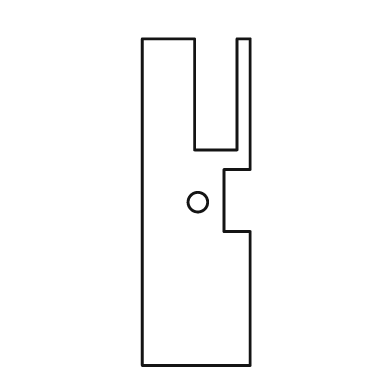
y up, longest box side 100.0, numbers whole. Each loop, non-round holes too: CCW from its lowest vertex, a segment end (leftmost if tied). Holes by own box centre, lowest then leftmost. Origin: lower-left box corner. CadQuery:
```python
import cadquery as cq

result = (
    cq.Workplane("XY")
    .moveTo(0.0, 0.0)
    .lineTo(33.0, 0.0)
    .lineTo(33.0, 41.0)
    .lineTo(25.0, 41.0)
    .lineTo(25.0, 60.0)
    .lineTo(33.0, 60.0)
    .lineTo(33.0, 100.0)
    .lineTo(29.0, 100.0)
    .lineTo(29.0, 66.0)
    .lineTo(16.0, 66.0)
    .lineTo(16.0, 100.0)
    .lineTo(0.0, 100.0)
    .close()
    .moveTo(17.0, 50.0)
    .circle(3.0)
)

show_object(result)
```